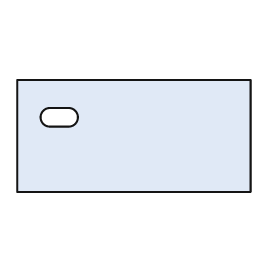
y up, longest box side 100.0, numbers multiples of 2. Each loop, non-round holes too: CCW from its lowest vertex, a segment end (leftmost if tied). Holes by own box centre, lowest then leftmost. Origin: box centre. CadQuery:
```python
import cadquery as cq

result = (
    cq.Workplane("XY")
    .moveTo(-50.0, -24.0)
    .lineTo(50.0, -24.0)
    .lineTo(50.0, 24.0)
    .lineTo(-50.0, 24.0)
    .close()
    .moveTo(-36.0, 4.0)
    .lineTo(-28.0, 4.0)
    .threePointArc((-24.0, 8.0), (-28.0, 12.0))
    .lineTo(-36.0, 12.0)
    .threePointArc((-40.0, 8.0), (-36.0, 4.0))
    .close()
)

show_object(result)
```